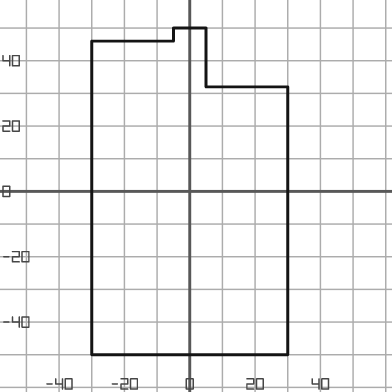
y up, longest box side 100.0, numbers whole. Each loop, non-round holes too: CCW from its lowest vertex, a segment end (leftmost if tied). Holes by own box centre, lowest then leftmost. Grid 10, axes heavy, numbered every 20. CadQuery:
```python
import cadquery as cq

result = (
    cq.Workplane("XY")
    .moveTo(-30.0, -50.0)
    .lineTo(30.0, -50.0)
    .lineTo(30.0, 32.0)
    .lineTo(5.0, 32.0)
    .lineTo(5.0, 50.0)
    .lineTo(-5.0, 50.0)
    .lineTo(-5.0, 46.0)
    .lineTo(-30.0, 46.0)
    .close()
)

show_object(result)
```